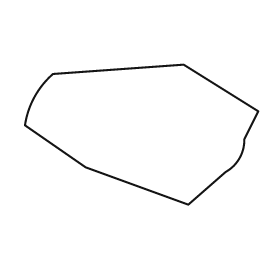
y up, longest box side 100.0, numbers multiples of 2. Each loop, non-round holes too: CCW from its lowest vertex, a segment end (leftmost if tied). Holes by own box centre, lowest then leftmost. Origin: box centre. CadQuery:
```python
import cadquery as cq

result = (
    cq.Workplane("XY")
    .moveTo(20.0, -30.0)
    .lineTo(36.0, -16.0)
    .threePointArc((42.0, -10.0), (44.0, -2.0))
    .lineTo(50.0, 10.0)
    .lineTo(18.0, 30.0)
    .lineTo(-38.0, 26.0)
    .threePointArc((-46.0, 16.0), (-50.0, 4.0))
    .lineTo(-24.0, -14.0)
    .close()
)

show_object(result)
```